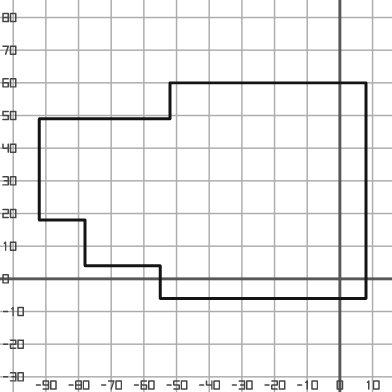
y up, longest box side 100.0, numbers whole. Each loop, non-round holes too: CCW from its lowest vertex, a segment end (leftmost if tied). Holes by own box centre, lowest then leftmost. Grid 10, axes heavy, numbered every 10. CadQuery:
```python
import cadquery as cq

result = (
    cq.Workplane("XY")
    .moveTo(-55.0, -6.0)
    .lineTo(8.0, -6.0)
    .lineTo(8.0, 60.0)
    .lineTo(-52.0, 60.0)
    .lineTo(-52.0, 49.0)
    .lineTo(-92.0, 49.0)
    .lineTo(-92.0, 18.0)
    .lineTo(-78.0, 18.0)
    .lineTo(-78.0, 4.0)
    .lineTo(-55.0, 4.0)
    .close()
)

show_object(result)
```